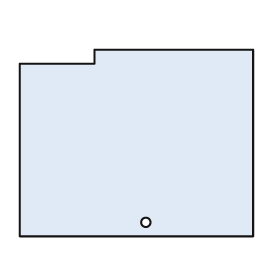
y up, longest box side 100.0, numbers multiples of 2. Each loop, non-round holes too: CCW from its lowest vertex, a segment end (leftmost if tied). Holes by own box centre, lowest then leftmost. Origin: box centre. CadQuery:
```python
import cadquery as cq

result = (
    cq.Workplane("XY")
    .moveTo(-50.0, -40.0)
    .lineTo(50.0, -40.0)
    .lineTo(50.0, 40.0)
    .lineTo(-18.0, 40.0)
    .lineTo(-18.0, 34.0)
    .lineTo(-50.0, 34.0)
    .close()
    .moveTo(4.0, -34.0)
    .circle(2.0)
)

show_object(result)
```